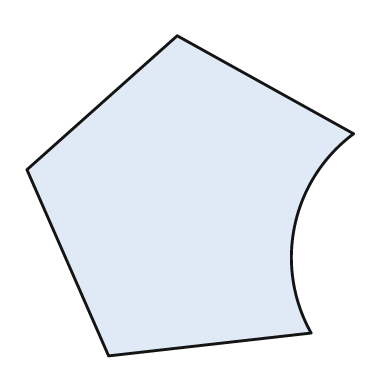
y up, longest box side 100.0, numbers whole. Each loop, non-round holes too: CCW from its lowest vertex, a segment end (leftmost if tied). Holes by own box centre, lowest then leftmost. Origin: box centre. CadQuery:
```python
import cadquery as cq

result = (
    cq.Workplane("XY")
    .moveTo(-25.0, -49.0)
    .lineTo(37.0, -42.0)
    .threePointArc((32.0, -9.0), (50.0, 19.0))
    .lineTo(-4.0, 49.0)
    .lineTo(-50.0, 8.0)
    .close()
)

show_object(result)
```